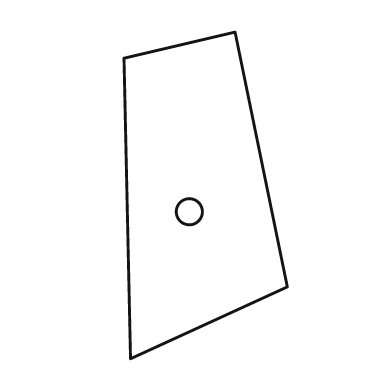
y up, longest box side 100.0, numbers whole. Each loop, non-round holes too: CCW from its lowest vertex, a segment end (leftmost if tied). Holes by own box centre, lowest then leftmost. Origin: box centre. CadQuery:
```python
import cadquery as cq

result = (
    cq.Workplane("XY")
    .moveTo(-23.0, -50.0)
    .lineTo(25.0, -28.0)
    .lineTo(9.0, 50.0)
    .lineTo(-25.0, 42.0)
    .close()
    .moveTo(-5.0, -5.0)
    .circle(4.0)
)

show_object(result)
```